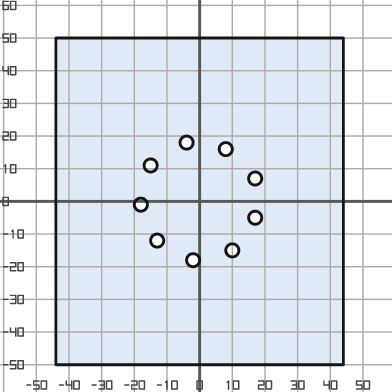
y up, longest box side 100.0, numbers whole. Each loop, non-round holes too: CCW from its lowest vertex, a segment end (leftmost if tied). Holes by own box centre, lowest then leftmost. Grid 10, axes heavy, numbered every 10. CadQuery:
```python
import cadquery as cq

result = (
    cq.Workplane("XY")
    .moveTo(-44.0, -50.0)
    .lineTo(44.0, -50.0)
    .lineTo(44.0, 50.0)
    .lineTo(-44.0, 50.0)
    .close()
    .moveTo(-2.0, -18.0)
    .circle(2.0)
    .moveTo(10.0, -15.0)
    .circle(2.0)
    .moveTo(-13.0, -12.0)
    .circle(2.0)
    .moveTo(17.0, -5.0)
    .circle(2.0)
    .moveTo(-18.0, -1.0)
    .circle(2.0)
    .moveTo(17.0, 7.0)
    .circle(2.0)
    .moveTo(-15.0, 11.0)
    .circle(2.0)
    .moveTo(8.0, 16.0)
    .circle(2.0)
    .moveTo(-4.0, 18.0)
    .circle(2.0)
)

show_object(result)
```